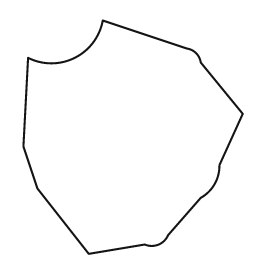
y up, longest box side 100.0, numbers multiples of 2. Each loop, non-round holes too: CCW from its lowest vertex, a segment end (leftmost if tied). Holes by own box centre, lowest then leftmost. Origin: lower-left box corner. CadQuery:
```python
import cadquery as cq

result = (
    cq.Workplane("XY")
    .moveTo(28.0, 0.0)
    .lineTo(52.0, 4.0)
    .threePointArc((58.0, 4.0), (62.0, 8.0))
    .lineTo(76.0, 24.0)
    .threePointArc((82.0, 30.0), (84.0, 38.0))
    .lineTo(94.0, 60.0)
    .lineTo(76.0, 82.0)
    .threePointArc((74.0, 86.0), (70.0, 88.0))
    .lineTo(34.0, 100.0)
    .threePointArc((22.0, 84.0), (2.0, 84.0))
    .lineTo(0.0, 46.0)
    .lineTo(6.0, 28.0)
    .close()
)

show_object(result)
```